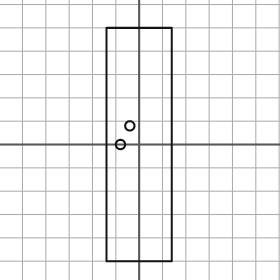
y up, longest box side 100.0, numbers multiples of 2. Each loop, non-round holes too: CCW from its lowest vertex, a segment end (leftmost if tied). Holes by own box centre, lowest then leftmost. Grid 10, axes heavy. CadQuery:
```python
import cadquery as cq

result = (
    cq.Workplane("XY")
    .moveTo(-14.0, -50.0)
    .lineTo(14.0, -50.0)
    .lineTo(14.0, 50.0)
    .lineTo(-14.0, 50.0)
    .close()
    .moveTo(-8.0, 0.0)
    .circle(2.0)
    .moveTo(-4.0, 8.0)
    .circle(2.0)
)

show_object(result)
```